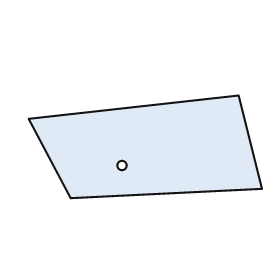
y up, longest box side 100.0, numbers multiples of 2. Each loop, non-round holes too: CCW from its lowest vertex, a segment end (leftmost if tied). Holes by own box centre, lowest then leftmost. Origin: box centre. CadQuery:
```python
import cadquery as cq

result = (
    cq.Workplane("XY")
    .moveTo(-32.0, -22.0)
    .lineTo(50.0, -18.0)
    .lineTo(40.0, 22.0)
    .lineTo(-50.0, 12.0)
    .close()
    .moveTo(-10.0, -8.0)
    .circle(2.0)
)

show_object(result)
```